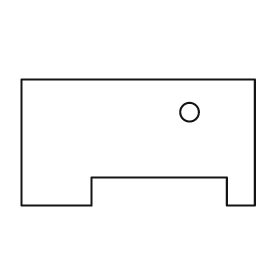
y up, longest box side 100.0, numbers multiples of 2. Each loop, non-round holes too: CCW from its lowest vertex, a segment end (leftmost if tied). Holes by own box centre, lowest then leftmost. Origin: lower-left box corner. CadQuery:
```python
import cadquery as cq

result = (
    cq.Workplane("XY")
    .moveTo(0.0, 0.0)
    .lineTo(30.0, 0.0)
    .lineTo(30.0, 12.0)
    .lineTo(88.0, 12.0)
    .lineTo(88.0, 0.0)
    .lineTo(100.0, 0.0)
    .lineTo(100.0, 54.0)
    .lineTo(0.0, 54.0)
    .close()
    .moveTo(72.0, 40.0)
    .circle(4.0)
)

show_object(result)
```